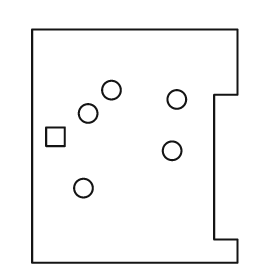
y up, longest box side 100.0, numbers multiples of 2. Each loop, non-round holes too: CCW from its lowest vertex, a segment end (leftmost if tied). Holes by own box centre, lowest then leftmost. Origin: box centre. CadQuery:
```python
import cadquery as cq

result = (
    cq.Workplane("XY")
    .moveTo(-44.0, -50.0)
    .lineTo(44.0, -50.0)
    .lineTo(44.0, -40.0)
    .lineTo(34.0, -40.0)
    .lineTo(34.0, 22.0)
    .lineTo(44.0, 22.0)
    .lineTo(44.0, 50.0)
    .lineTo(-44.0, 50.0)
    .close()
    .moveTo(-22.0, -18.0)
    .circle(4.0)
    .moveTo(16.0, -2.0)
    .circle(4.0)
    .moveTo(-38.0, 0.0)
    .lineTo(-30.0, 0.0)
    .lineTo(-30.0, 8.0)
    .lineTo(-38.0, 8.0)
    .close()
    .moveTo(-20.0, 14.0)
    .circle(4.0)
    .moveTo(18.0, 20.0)
    .circle(4.0)
    .moveTo(-10.0, 24.0)
    .circle(4.0)
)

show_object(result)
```